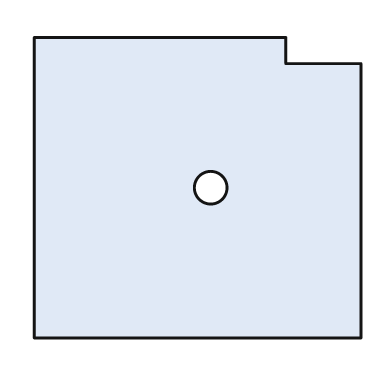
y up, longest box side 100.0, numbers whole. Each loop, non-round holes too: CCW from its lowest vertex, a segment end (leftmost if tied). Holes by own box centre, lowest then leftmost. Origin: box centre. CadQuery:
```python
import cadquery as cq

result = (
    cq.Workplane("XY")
    .moveTo(-50.0, -46.0)
    .lineTo(50.0, -46.0)
    .lineTo(50.0, 38.0)
    .lineTo(27.0, 38.0)
    .lineTo(27.0, 46.0)
    .lineTo(-50.0, 46.0)
    .close()
    .moveTo(4.0, 0.0)
    .circle(5.0)
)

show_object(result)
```